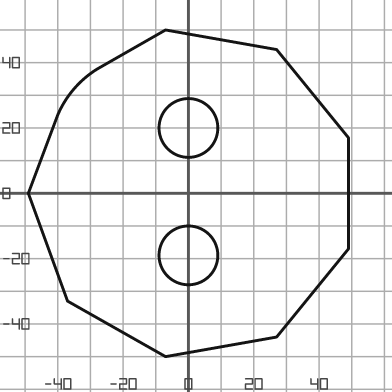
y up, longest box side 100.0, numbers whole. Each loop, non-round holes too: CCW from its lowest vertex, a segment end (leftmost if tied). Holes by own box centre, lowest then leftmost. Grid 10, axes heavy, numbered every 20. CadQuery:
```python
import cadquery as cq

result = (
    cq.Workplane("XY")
    .moveTo(-7.0, -50.0)
    .lineTo(27.0, -44.0)
    .lineTo(49.0, -17.0)
    .lineTo(49.0, 17.0)
    .lineTo(27.0, 44.0)
    .lineTo(-7.0, 50.0)
    .lineTo(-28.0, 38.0)
    .threePointArc((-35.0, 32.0), (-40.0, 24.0))
    .lineTo(-49.0, 0.0)
    .lineTo(-37.0, -33.0)
    .close()
    .moveTo(0.0, -19.0)
    .circle(9.0)
    .moveTo(0.0, 20.0)
    .circle(9.0)
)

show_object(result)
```